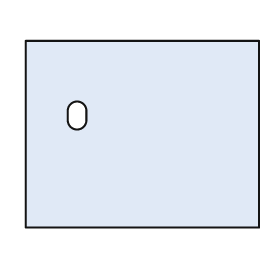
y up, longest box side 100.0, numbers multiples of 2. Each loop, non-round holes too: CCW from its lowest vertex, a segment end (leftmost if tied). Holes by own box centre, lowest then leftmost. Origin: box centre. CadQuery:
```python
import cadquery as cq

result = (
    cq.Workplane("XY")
    .moveTo(-50.0, -40.0)
    .lineTo(50.0, -40.0)
    .lineTo(50.0, 40.0)
    .lineTo(-50.0, 40.0)
    .close()
    .moveTo(-32.0, 6.0)
    .threePointArc((-28.0, 2.0), (-24.0, 6.0))
    .lineTo(-24.0, 10.0)
    .threePointArc((-28.0, 14.0), (-32.0, 10.0))
    .close()
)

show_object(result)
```